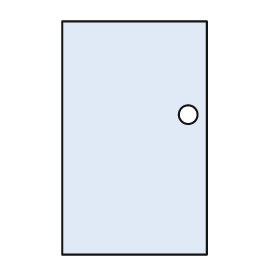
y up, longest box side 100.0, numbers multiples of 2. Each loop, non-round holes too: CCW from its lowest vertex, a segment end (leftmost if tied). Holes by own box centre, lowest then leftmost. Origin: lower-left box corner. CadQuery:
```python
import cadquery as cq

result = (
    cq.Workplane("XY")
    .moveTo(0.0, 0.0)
    .lineTo(62.0, 0.0)
    .lineTo(62.0, 100.0)
    .lineTo(0.0, 100.0)
    .close()
    .moveTo(54.0, 60.0)
    .circle(4.0)
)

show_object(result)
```